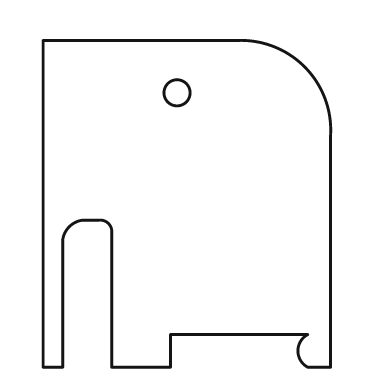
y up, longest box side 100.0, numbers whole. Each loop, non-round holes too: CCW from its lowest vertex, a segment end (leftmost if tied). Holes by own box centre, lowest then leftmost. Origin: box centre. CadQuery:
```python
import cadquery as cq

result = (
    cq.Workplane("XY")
    .moveTo(-44.0, -50.0)
    .lineTo(-38.0, -50.0)
    .lineTo(-38.0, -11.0)
    .threePointArc((-36.0, -7.0), (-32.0, -5.0))
    .lineTo(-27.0, -5.0)
    .threePointArc((-24.0, -6.0), (-23.0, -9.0))
    .lineTo(-23.0, -50.0)
    .lineTo(-5.0, -50.0)
    .lineTo(-5.0, -40.0)
    .lineTo(37.0, -40.0)
    .threePointArc((34.0, -45.0), (37.0, -50.0))
    .lineTo(44.0, -50.0)
    .lineTo(44.0, 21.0)
    .threePointArc((36.0, 42.0), (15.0, 50.0))
    .lineTo(-44.0, 50.0)
    .close()
    .moveTo(-3.0, 34.0)
    .circle(4.0)
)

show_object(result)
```